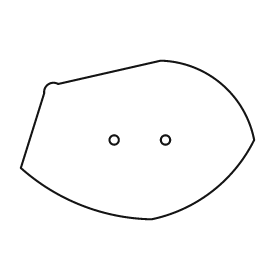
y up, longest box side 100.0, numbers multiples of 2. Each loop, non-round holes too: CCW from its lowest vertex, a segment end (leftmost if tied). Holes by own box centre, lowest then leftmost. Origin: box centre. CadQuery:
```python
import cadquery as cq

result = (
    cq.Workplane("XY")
    .moveTo(6.0, -34.0)
    .threePointArc((32.0, -22.0), (50.0, 0.0))
    .threePointArc((36.0, 24.0), (10.0, 34.0))
    .lineTo(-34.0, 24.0)
    .threePointArc((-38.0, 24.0), (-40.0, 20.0))
    .lineTo(-50.0, -12.0)
    .threePointArc((-24.0, -28.0), (6.0, -34.0))
    .close()
    .moveTo(-10.0, 0.0)
    .circle(2.0)
    .moveTo(12.0, 0.0)
    .circle(2.0)
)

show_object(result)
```